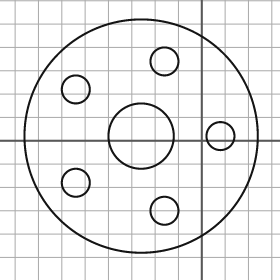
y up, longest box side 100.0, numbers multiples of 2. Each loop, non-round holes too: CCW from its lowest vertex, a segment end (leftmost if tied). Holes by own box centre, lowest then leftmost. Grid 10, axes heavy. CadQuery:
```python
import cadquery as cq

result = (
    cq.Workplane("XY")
    .moveTo(-26.0, 2.0)
    .circle(50.0)
    .moveTo(-16.0, -30.0)
    .circle(6.0)
    .moveTo(-54.0, -18.0)
    .circle(6.0)
    .moveTo(-26.0, 2.0)
    .circle(14.0)
    .moveTo(8.0, 2.0)
    .circle(6.0)
    .moveTo(-54.0, 22.0)
    .circle(6.0)
    .moveTo(-16.0, 34.0)
    .circle(6.0)
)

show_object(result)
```